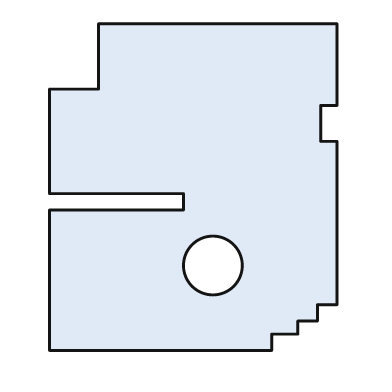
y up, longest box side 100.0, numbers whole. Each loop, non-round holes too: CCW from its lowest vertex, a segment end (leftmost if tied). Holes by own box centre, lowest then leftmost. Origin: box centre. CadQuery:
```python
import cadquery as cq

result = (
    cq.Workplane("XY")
    .moveTo(-44.0, -50.0)
    .lineTo(24.0, -50.0)
    .lineTo(24.0, -45.0)
    .lineTo(32.0, -45.0)
    .lineTo(32.0, -41.0)
    .lineTo(38.0, -41.0)
    .lineTo(38.0, -36.0)
    .lineTo(44.0, -36.0)
    .lineTo(44.0, 14.0)
    .lineTo(39.0, 14.0)
    .lineTo(39.0, 25.0)
    .lineTo(44.0, 25.0)
    .lineTo(44.0, 50.0)
    .lineTo(-29.0, 50.0)
    .lineTo(-29.0, 30.0)
    .lineTo(-44.0, 30.0)
    .lineTo(-44.0, -2.0)
    .lineTo(-3.0, -2.0)
    .lineTo(-3.0, -7.0)
    .lineTo(-44.0, -7.0)
    .close()
    .moveTo(6.0, -24.0)
    .circle(9.0)
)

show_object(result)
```